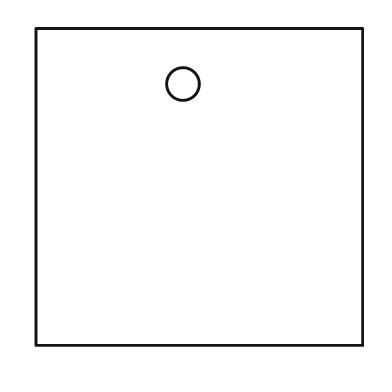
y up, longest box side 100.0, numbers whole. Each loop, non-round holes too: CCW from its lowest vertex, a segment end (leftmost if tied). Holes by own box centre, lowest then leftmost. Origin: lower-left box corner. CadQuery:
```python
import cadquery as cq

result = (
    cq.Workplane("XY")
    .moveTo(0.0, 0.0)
    .lineTo(100.0, 0.0)
    .lineTo(100.0, 97.0)
    .lineTo(0.0, 97.0)
    .close()
    .moveTo(45.0, 80.0)
    .circle(5.0)
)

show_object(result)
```